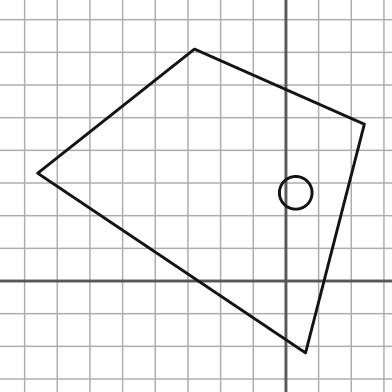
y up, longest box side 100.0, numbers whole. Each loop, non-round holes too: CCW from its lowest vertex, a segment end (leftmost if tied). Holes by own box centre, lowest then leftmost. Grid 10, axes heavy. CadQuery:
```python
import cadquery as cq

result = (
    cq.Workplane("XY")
    .moveTo(6.0, -22.0)
    .lineTo(24.0, 48.0)
    .lineTo(-28.0, 71.0)
    .lineTo(-76.0, 33.0)
    .close()
    .moveTo(3.0, 27.0)
    .circle(5.0)
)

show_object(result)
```